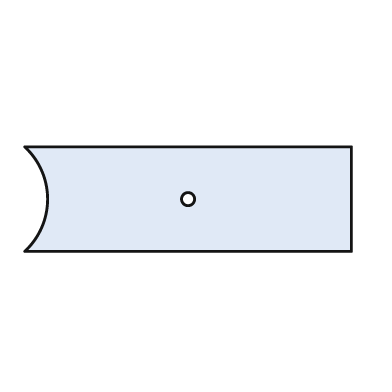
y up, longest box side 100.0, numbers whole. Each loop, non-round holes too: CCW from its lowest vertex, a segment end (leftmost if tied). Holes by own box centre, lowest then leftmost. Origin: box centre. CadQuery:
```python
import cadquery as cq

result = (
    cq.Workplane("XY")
    .moveTo(-50.0, -16.0)
    .lineTo(50.0, -16.0)
    .lineTo(50.0, 16.0)
    .lineTo(-50.0, 16.0)
    .threePointArc((-43.0, 0.0), (-50.0, -16.0))
    .close()
    .moveTo(0.0, 0.0)
    .circle(2.0)
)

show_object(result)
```